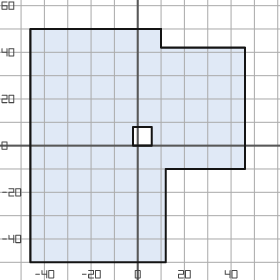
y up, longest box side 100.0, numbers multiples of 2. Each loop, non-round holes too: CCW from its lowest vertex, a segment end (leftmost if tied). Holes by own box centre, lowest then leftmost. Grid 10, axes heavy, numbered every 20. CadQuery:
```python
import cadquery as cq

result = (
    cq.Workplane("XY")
    .moveTo(-46.0, -50.0)
    .lineTo(12.0, -50.0)
    .lineTo(12.0, -10.0)
    .lineTo(46.0, -10.0)
    .lineTo(46.0, 42.0)
    .lineTo(10.0, 42.0)
    .lineTo(10.0, 50.0)
    .lineTo(-46.0, 50.0)
    .close()
    .moveTo(-2.0, 0.0)
    .lineTo(6.0, 0.0)
    .lineTo(6.0, 8.0)
    .lineTo(-2.0, 8.0)
    .close()
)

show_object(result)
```